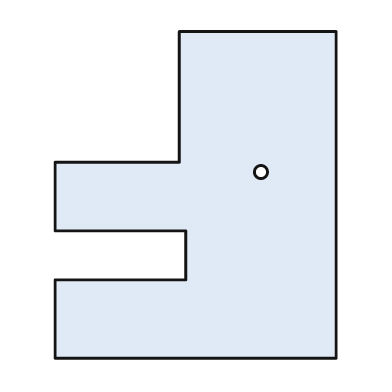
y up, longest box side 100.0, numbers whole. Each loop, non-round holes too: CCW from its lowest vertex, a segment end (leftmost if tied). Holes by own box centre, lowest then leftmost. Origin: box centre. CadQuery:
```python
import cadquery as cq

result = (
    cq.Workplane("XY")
    .moveTo(-43.0, -50.0)
    .lineTo(43.0, -50.0)
    .lineTo(43.0, 50.0)
    .lineTo(-5.0, 50.0)
    .lineTo(-5.0, 10.0)
    .lineTo(-43.0, 10.0)
    .lineTo(-43.0, -11.0)
    .lineTo(-3.0, -11.0)
    .lineTo(-3.0, -26.0)
    .lineTo(-43.0, -26.0)
    .close()
    .moveTo(20.0, 7.0)
    .circle(2.0)
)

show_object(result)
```